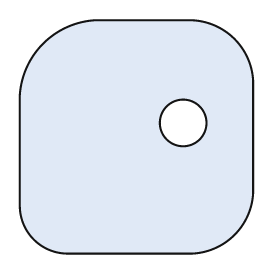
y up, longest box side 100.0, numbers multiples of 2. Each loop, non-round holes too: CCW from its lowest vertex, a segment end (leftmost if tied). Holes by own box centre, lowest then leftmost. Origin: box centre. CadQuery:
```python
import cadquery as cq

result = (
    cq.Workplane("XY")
    .moveTo(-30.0, -50.0)
    .lineTo(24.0, -50.0)
    .threePointArc((42.0, -42.0), (50.0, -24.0))
    .lineTo(50.0, 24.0)
    .threePointArc((42.0, 42.0), (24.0, 50.0))
    .lineTo(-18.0, 50.0)
    .threePointArc((-40.0, 40.0), (-50.0, 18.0))
    .lineTo(-50.0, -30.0)
    .threePointArc((-44.0, -44.0), (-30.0, -50.0))
    .close()
    .moveTo(20.0, 6.0)
    .circle(10.0)
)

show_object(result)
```